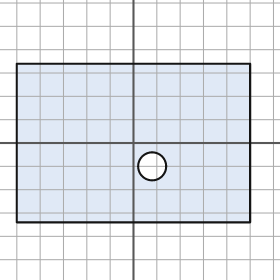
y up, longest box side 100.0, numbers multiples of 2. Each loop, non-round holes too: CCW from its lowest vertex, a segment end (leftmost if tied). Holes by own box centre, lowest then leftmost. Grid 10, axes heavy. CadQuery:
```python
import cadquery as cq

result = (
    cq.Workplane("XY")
    .moveTo(-50.0, -34.0)
    .lineTo(50.0, -34.0)
    .lineTo(50.0, 34.0)
    .lineTo(-50.0, 34.0)
    .close()
    .moveTo(8.0, -10.0)
    .circle(6.0)
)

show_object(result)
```